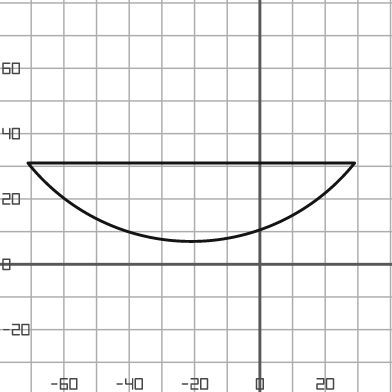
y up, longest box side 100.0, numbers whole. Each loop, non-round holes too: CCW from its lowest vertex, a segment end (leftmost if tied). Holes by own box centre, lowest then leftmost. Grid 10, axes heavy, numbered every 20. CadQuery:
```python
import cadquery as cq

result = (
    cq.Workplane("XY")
    .moveTo(-71.0, 31.0)
    .threePointArc((-21.0, 7.0), (29.0, 31.0))
    .close()
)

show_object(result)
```